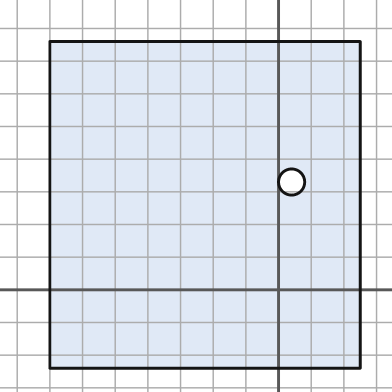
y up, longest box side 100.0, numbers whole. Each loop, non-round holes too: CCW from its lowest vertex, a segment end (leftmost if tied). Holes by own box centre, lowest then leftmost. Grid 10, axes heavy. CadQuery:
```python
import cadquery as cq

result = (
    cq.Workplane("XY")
    .moveTo(-70.0, -24.0)
    .lineTo(25.0, -24.0)
    .lineTo(25.0, 76.0)
    .lineTo(-70.0, 76.0)
    .close()
    .moveTo(4.0, 33.0)
    .circle(4.0)
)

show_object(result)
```